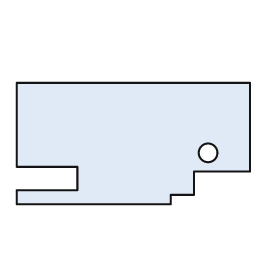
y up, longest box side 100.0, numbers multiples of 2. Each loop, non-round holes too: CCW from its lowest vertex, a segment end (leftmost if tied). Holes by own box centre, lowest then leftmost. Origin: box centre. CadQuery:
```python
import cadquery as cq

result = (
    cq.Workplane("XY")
    .moveTo(-50.0, -26.0)
    .lineTo(16.0, -26.0)
    .lineTo(16.0, -22.0)
    .lineTo(26.0, -22.0)
    .lineTo(26.0, -12.0)
    .lineTo(50.0, -12.0)
    .lineTo(50.0, 26.0)
    .lineTo(-50.0, 26.0)
    .lineTo(-50.0, -10.0)
    .lineTo(-24.0, -10.0)
    .lineTo(-24.0, -20.0)
    .lineTo(-50.0, -20.0)
    .close()
    .moveTo(32.0, -4.0)
    .circle(4.0)
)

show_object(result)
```